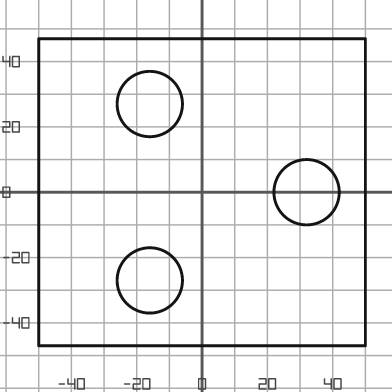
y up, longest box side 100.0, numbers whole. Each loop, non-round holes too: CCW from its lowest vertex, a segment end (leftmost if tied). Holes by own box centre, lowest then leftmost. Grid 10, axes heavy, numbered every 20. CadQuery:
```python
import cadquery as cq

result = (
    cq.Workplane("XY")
    .moveTo(-50.0, -47.0)
    .lineTo(50.0, -47.0)
    .lineTo(50.0, 47.0)
    .lineTo(-50.0, 47.0)
    .close()
    .moveTo(-16.0, -27.0)
    .circle(10.0)
    .moveTo(32.0, 0.0)
    .circle(10.0)
    .moveTo(-16.0, 27.0)
    .circle(10.0)
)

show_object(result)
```